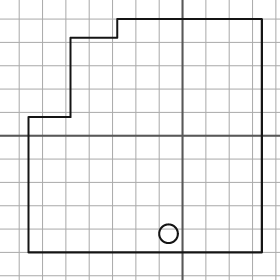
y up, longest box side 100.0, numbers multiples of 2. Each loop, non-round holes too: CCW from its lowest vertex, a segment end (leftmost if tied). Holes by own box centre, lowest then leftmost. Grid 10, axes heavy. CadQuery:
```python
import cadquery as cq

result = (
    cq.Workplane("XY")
    .moveTo(-66.0, -50.0)
    .lineTo(34.0, -50.0)
    .lineTo(34.0, 50.0)
    .lineTo(-28.0, 50.0)
    .lineTo(-28.0, 42.0)
    .lineTo(-48.0, 42.0)
    .lineTo(-48.0, 8.0)
    .lineTo(-66.0, 8.0)
    .close()
    .moveTo(-6.0, -42.0)
    .circle(4.0)
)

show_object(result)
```